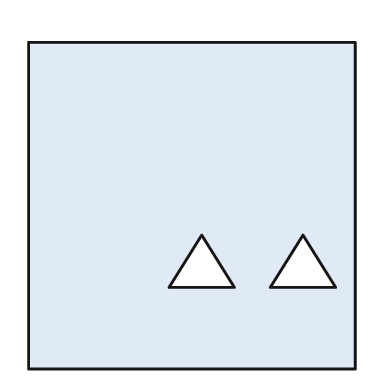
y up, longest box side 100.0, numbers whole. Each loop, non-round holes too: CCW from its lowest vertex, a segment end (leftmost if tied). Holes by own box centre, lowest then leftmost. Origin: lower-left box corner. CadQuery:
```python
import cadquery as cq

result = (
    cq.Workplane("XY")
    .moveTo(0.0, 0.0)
    .lineTo(100.0, 0.0)
    .lineTo(100.0, 100.0)
    .lineTo(0.0, 100.0)
    .close()
    .moveTo(43.0, 25.0)
    .lineTo(63.0, 25.0)
    .lineTo(53.0, 41.0)
    .close()
    .moveTo(74.0, 25.0)
    .lineTo(94.0, 25.0)
    .lineTo(84.0, 41.0)
    .close()
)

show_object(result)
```